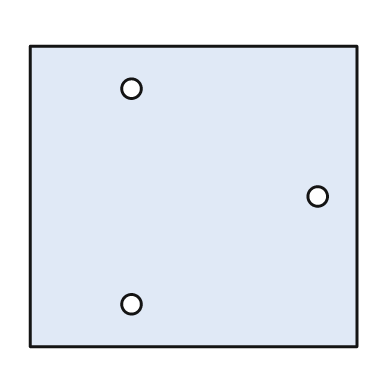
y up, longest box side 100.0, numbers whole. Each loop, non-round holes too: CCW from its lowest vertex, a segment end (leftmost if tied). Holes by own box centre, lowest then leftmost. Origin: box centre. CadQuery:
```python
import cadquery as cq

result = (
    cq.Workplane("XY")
    .moveTo(-50.0, -46.0)
    .lineTo(50.0, -46.0)
    .lineTo(50.0, 46.0)
    .lineTo(-50.0, 46.0)
    .close()
    .moveTo(-19.0, -33.0)
    .circle(3.0)
    .moveTo(38.0, 0.0)
    .circle(3.0)
    .moveTo(-19.0, 33.0)
    .circle(3.0)
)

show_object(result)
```